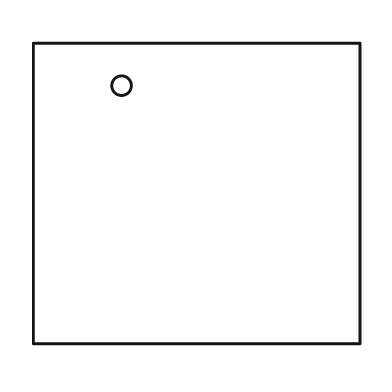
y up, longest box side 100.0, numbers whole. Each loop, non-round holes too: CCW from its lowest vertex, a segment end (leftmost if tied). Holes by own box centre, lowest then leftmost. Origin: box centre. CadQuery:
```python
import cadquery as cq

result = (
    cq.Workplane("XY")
    .moveTo(-50.0, -46.0)
    .lineTo(50.0, -46.0)
    .lineTo(50.0, 46.0)
    .lineTo(-50.0, 46.0)
    .close()
    .moveTo(-23.0, 33.0)
    .circle(3.0)
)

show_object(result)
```